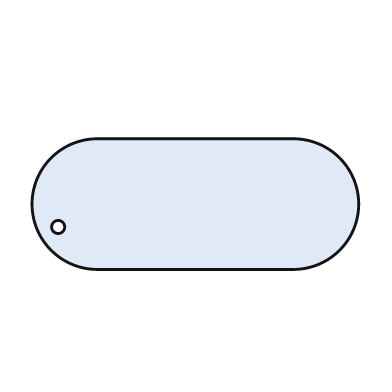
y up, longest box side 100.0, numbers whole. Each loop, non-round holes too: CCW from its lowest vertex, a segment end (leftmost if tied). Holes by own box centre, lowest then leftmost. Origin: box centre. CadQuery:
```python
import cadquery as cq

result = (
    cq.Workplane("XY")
    .moveTo(-30.0, -20.0)
    .lineTo(30.0, -20.0)
    .threePointArc((50.0, 0.0), (30.0, 20.0))
    .lineTo(-30.0, 20.0)
    .threePointArc((-50.0, 0.0), (-30.0, -20.0))
    .close()
    .moveTo(-42.0, -7.0)
    .circle(2.0)
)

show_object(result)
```